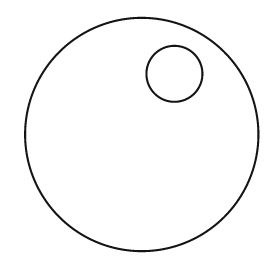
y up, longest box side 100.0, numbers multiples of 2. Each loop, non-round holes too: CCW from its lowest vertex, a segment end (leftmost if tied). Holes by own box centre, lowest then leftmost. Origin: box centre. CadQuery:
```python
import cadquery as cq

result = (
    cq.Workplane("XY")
    .moveTo(0.0, 0.0)
    .circle(50.0)
    .moveTo(14.0, 26.0)
    .circle(12.0)
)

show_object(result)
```